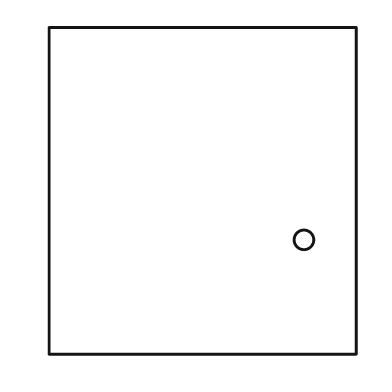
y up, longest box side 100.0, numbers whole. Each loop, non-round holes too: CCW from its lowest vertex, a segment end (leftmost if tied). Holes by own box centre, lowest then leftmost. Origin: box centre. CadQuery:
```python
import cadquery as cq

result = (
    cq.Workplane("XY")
    .moveTo(-47.0, -50.0)
    .lineTo(47.0, -50.0)
    .lineTo(47.0, 50.0)
    .lineTo(-47.0, 50.0)
    .close()
    .moveTo(31.0, -15.0)
    .circle(3.0)
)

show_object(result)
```